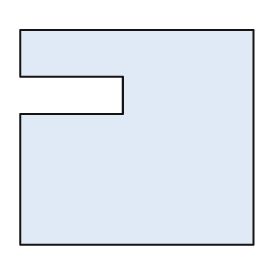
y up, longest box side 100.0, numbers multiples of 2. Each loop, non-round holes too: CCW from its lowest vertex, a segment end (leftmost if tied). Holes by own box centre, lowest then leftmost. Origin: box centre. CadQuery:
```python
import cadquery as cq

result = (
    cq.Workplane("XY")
    .moveTo(-50.0, -46.0)
    .lineTo(50.0, -46.0)
    .lineTo(50.0, 46.0)
    .lineTo(-50.0, 46.0)
    .lineTo(-50.0, 26.0)
    .lineTo(-6.0, 26.0)
    .lineTo(-6.0, 10.0)
    .lineTo(-50.0, 10.0)
    .close()
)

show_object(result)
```